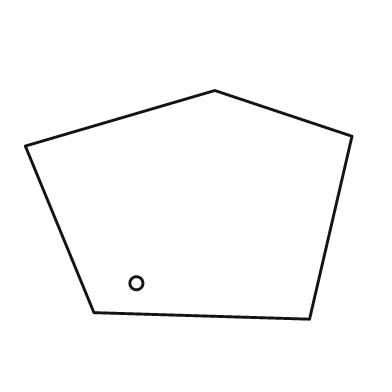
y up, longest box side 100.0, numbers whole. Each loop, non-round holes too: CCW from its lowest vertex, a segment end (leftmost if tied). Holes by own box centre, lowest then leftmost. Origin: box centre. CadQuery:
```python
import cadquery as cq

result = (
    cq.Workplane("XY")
    .moveTo(37.0, -35.0)
    .lineTo(50.0, 21.0)
    .lineTo(8.0, 35.0)
    .lineTo(-50.0, 18.0)
    .lineTo(-29.0, -33.0)
    .close()
    .moveTo(-16.0, -24.0)
    .circle(2.0)
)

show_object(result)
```